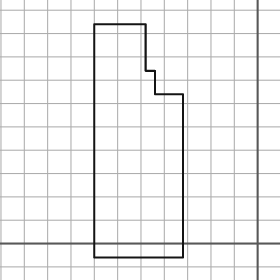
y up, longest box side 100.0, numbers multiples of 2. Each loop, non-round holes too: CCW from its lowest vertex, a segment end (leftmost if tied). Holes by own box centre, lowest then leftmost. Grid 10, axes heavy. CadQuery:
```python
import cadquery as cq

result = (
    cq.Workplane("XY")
    .moveTo(-70.0, -6.0)
    .lineTo(-32.0, -6.0)
    .lineTo(-32.0, 64.0)
    .lineTo(-44.0, 64.0)
    .lineTo(-44.0, 74.0)
    .lineTo(-48.0, 74.0)
    .lineTo(-48.0, 94.0)
    .lineTo(-70.0, 94.0)
    .close()
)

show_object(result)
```